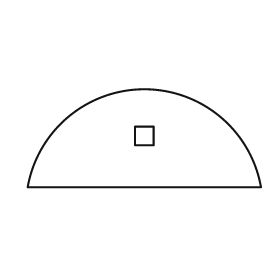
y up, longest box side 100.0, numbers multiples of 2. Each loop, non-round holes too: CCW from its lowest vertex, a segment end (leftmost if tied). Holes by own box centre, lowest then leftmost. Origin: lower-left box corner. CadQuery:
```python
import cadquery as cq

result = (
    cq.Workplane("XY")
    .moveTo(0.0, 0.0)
    .lineTo(100.0, 0.0)
    .threePointArc((50.0, 42.0), (0.0, 0.0))
    .close()
    .moveTo(46.0, 18.0)
    .lineTo(54.0, 18.0)
    .lineTo(54.0, 26.0)
    .lineTo(46.0, 26.0)
    .close()
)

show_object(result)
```